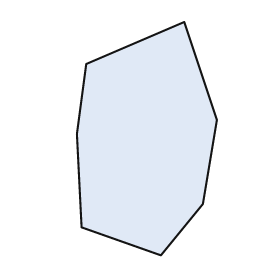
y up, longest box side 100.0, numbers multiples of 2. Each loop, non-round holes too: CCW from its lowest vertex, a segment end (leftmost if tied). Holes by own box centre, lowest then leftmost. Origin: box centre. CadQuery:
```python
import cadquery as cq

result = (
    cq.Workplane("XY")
    .moveTo(6.0, -50.0)
    .lineTo(24.0, -28.0)
    .lineTo(30.0, 8.0)
    .lineTo(16.0, 50.0)
    .lineTo(-26.0, 32.0)
    .lineTo(-30.0, 2.0)
    .lineTo(-28.0, -38.0)
    .close()
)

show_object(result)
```